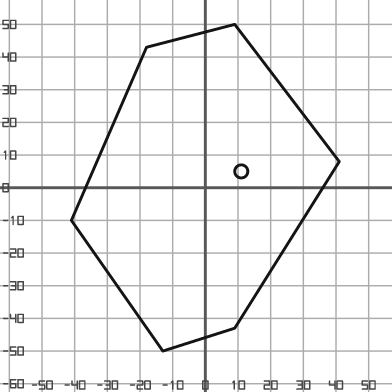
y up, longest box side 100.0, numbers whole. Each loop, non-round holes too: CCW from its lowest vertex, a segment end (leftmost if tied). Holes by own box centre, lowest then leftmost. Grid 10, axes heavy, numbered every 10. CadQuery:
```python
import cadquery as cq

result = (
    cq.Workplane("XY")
    .moveTo(-13.0, -50.0)
    .lineTo(9.0, -43.0)
    .lineTo(41.0, 8.0)
    .lineTo(9.0, 50.0)
    .lineTo(-18.0, 43.0)
    .lineTo(-41.0, -10.0)
    .close()
    .moveTo(11.0, 5.0)
    .circle(2.0)
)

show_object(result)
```